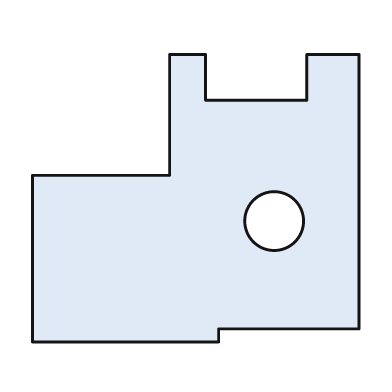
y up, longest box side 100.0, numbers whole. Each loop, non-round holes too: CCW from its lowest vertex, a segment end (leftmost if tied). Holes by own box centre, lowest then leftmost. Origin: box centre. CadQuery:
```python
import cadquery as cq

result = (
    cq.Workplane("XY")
    .moveTo(-50.0, -44.0)
    .lineTo(7.0, -44.0)
    .lineTo(7.0, -40.0)
    .lineTo(50.0, -40.0)
    .lineTo(50.0, 44.0)
    .lineTo(34.0, 44.0)
    .lineTo(34.0, 30.0)
    .lineTo(3.0, 30.0)
    .lineTo(3.0, 44.0)
    .lineTo(-8.0, 44.0)
    .lineTo(-8.0, 7.0)
    .lineTo(-50.0, 7.0)
    .close()
    .moveTo(24.0, -7.0)
    .circle(9.0)
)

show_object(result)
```